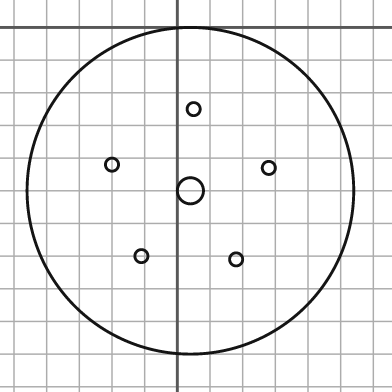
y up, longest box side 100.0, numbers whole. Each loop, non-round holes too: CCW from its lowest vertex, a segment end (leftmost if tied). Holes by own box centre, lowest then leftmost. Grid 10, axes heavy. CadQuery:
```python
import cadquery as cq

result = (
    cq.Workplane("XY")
    .moveTo(4.0, -50.0)
    .circle(50.0)
    .moveTo(18.0, -71.0)
    .circle(2.0)
    .moveTo(-11.0, -70.0)
    .circle(2.0)
    .moveTo(4.0, -50.0)
    .circle(4.0)
    .moveTo(28.0, -43.0)
    .circle(2.0)
    .moveTo(-20.0, -42.0)
    .circle(2.0)
    .moveTo(5.0, -25.0)
    .circle(2.0)
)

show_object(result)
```